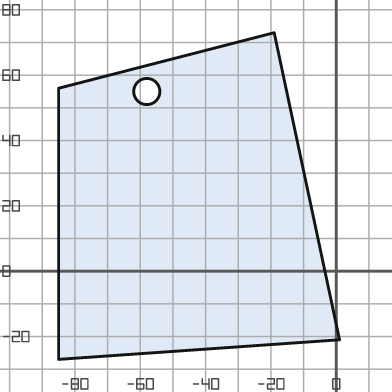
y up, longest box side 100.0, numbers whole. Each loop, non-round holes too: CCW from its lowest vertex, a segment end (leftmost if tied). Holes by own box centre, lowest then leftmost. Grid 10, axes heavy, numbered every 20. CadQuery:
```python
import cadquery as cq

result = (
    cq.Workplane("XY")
    .moveTo(-85.0, -27.0)
    .lineTo(1.0, -21.0)
    .lineTo(-19.0, 73.0)
    .lineTo(-85.0, 56.0)
    .close()
    .moveTo(-58.0, 55.0)
    .circle(4.0)
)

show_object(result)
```